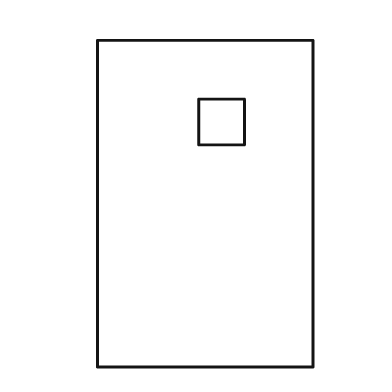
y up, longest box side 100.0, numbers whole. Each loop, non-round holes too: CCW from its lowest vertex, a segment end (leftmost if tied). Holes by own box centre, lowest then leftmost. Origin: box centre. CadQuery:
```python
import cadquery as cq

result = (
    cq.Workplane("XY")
    .moveTo(-33.0, -50.0)
    .lineTo(33.0, -50.0)
    .lineTo(33.0, 50.0)
    .lineTo(-33.0, 50.0)
    .close()
    .moveTo(-2.0, 18.0)
    .lineTo(12.0, 18.0)
    .lineTo(12.0, 32.0)
    .lineTo(-2.0, 32.0)
    .close()
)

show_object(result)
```